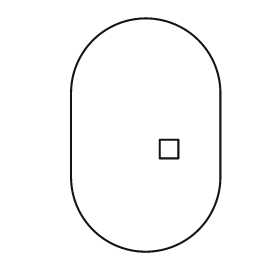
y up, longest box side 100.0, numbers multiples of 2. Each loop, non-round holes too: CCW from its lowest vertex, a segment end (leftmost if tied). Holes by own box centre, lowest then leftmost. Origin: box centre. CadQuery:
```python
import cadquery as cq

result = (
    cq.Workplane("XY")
    .moveTo(-32.0, -18.0)
    .threePointArc((0.0, -50.0), (32.0, -18.0))
    .lineTo(32.0, 18.0)
    .threePointArc((0.0, 50.0), (-32.0, 18.0))
    .close()
    .moveTo(6.0, -10.0)
    .lineTo(14.0, -10.0)
    .lineTo(14.0, -2.0)
    .lineTo(6.0, -2.0)
    .close()
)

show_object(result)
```